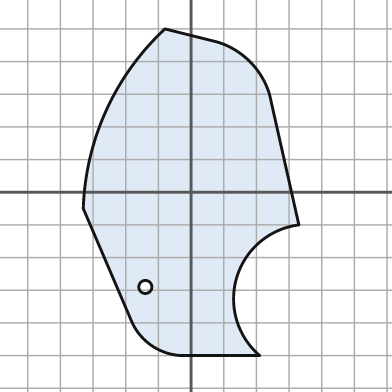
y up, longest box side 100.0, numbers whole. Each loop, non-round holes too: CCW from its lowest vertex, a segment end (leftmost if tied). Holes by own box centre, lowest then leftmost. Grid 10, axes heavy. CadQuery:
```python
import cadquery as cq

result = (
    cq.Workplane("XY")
    .moveTo(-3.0, -50.0)
    .lineTo(21.0, -50.0)
    .threePointArc((14.0, -26.0), (33.0, -10.0))
    .lineTo(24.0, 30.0)
    .threePointArc((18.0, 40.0), (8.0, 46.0))
    .lineTo(-8.0, 50.0)
    .threePointArc((-26.0, 25.0), (-33.0, -5.0))
    .lineTo(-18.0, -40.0)
    .threePointArc((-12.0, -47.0), (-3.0, -50.0))
    .close()
    .moveTo(-14.0, -29.0)
    .circle(2.0)
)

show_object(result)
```